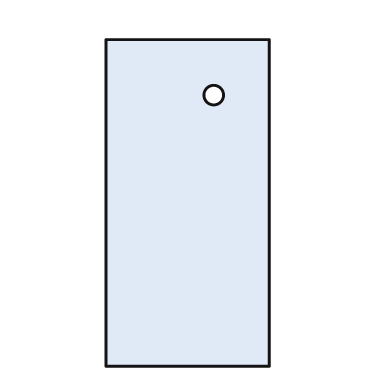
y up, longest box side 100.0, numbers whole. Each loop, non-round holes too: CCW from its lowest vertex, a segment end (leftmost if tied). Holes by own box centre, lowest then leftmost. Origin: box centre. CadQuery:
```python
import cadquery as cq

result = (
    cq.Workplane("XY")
    .moveTo(-25.0, -50.0)
    .lineTo(25.0, -50.0)
    .lineTo(25.0, 50.0)
    .lineTo(-25.0, 50.0)
    .close()
    .moveTo(8.0, 33.0)
    .circle(3.0)
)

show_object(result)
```